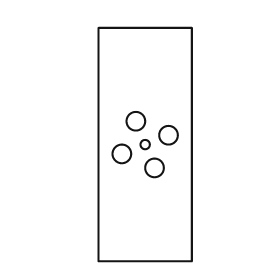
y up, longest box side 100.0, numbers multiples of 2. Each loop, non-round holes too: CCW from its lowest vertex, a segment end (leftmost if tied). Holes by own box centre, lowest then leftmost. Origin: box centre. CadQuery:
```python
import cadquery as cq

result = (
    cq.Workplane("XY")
    .moveTo(-20.0, -50.0)
    .lineTo(20.0, -50.0)
    .lineTo(20.0, 50.0)
    .lineTo(-20.0, 50.0)
    .close()
    .moveTo(4.0, -10.0)
    .circle(4.0)
    .moveTo(-10.0, -4.0)
    .circle(4.0)
    .moveTo(0.0, 0.0)
    .circle(2.0)
    .moveTo(10.0, 4.0)
    .circle(4.0)
    .moveTo(-4.0, 10.0)
    .circle(4.0)
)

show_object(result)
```